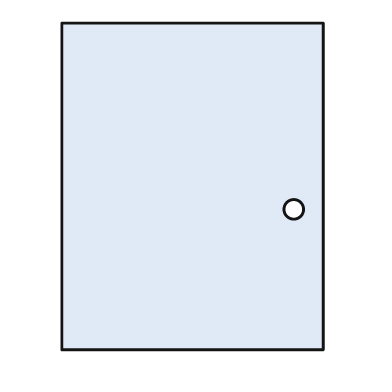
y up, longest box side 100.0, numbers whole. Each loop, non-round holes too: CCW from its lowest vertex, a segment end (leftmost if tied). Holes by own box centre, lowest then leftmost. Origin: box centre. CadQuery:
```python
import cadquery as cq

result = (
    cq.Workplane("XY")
    .moveTo(-40.0, -50.0)
    .lineTo(40.0, -50.0)
    .lineTo(40.0, 50.0)
    .lineTo(-40.0, 50.0)
    .close()
    .moveTo(31.0, -7.0)
    .circle(3.0)
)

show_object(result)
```